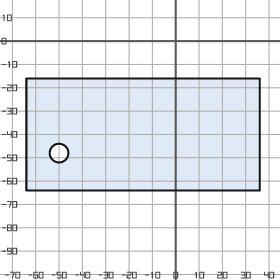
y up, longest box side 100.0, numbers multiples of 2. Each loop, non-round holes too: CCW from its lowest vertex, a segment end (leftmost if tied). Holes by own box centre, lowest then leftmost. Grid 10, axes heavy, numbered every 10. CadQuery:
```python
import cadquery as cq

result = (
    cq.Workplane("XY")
    .moveTo(-64.0, -64.0)
    .lineTo(36.0, -64.0)
    .lineTo(36.0, -16.0)
    .lineTo(-64.0, -16.0)
    .close()
    .moveTo(-50.0, -48.0)
    .circle(4.0)
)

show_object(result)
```